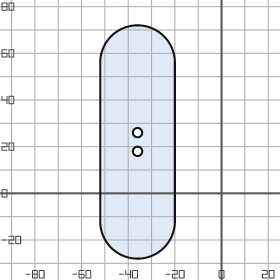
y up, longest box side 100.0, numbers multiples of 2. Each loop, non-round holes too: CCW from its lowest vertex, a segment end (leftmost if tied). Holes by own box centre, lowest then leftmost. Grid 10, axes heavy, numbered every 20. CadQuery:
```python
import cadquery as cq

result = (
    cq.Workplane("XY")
    .moveTo(-52.0, -12.0)
    .threePointArc((-36.0, -28.0), (-20.0, -12.0))
    .lineTo(-20.0, 56.0)
    .threePointArc((-36.0, 72.0), (-52.0, 56.0))
    .close()
    .moveTo(-36.0, 18.0)
    .circle(2.0)
    .moveTo(-36.0, 26.0)
    .circle(2.0)
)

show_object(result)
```